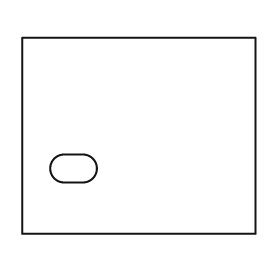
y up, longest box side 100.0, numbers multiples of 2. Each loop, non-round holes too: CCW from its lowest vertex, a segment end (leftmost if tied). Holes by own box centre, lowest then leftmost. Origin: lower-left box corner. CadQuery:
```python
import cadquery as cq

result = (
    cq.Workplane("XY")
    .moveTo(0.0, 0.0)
    .lineTo(100.0, 0.0)
    .lineTo(100.0, 84.0)
    .lineTo(0.0, 84.0)
    .close()
    .moveTo(18.0, 22.0)
    .lineTo(26.0, 22.0)
    .threePointArc((32.0, 28.0), (26.0, 34.0))
    .lineTo(18.0, 34.0)
    .threePointArc((12.0, 28.0), (18.0, 22.0))
    .close()
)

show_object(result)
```